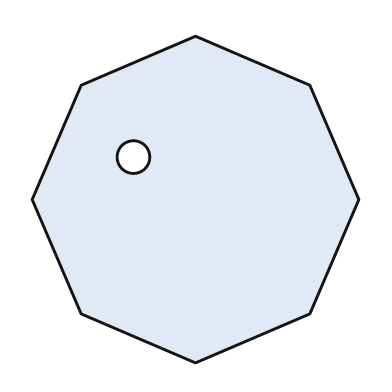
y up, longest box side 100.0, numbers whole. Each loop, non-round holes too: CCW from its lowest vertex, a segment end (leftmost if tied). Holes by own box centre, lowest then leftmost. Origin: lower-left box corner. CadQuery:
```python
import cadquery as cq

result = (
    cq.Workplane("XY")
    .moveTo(50.0, 0.0)
    .lineTo(85.0, 15.0)
    .lineTo(100.0, 50.0)
    .lineTo(85.0, 85.0)
    .lineTo(50.0, 100.0)
    .lineTo(15.0, 85.0)
    .lineTo(0.0, 50.0)
    .lineTo(15.0, 15.0)
    .close()
    .moveTo(31.0, 63.0)
    .circle(5.0)
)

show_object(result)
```